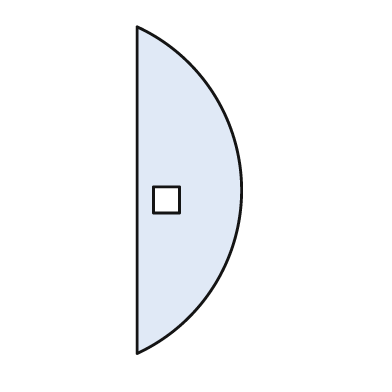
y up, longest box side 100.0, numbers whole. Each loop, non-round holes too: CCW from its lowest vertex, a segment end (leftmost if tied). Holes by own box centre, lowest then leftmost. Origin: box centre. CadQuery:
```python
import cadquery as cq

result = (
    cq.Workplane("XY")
    .moveTo(-16.0, -50.0)
    .threePointArc((16.0, 0.0), (-16.0, 50.0))
    .close()
    .moveTo(-11.0, -7.0)
    .lineTo(-3.0, -7.0)
    .lineTo(-3.0, 1.0)
    .lineTo(-11.0, 1.0)
    .close()
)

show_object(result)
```